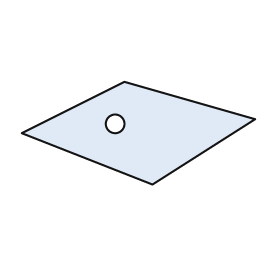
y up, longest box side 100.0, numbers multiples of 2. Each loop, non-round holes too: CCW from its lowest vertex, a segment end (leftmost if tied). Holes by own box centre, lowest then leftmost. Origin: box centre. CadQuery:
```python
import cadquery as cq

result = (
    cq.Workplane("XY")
    .moveTo(6.0, -22.0)
    .lineTo(50.0, 6.0)
    .lineTo(-6.0, 22.0)
    .lineTo(-50.0, 0.0)
    .close()
    .moveTo(-10.0, 4.0)
    .circle(4.0)
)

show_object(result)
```